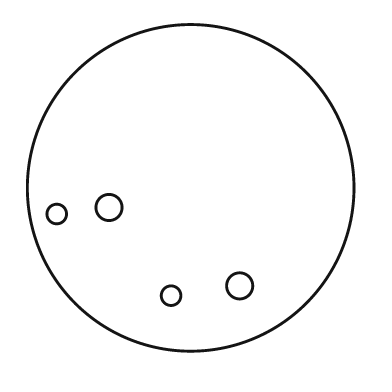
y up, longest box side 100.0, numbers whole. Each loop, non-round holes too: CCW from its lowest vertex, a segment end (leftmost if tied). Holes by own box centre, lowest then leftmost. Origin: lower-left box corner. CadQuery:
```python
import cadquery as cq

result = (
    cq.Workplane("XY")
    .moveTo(50.0, 50.0)
    .circle(50.0)
    .moveTo(44.0, 17.0)
    .circle(3.0)
    .moveTo(65.0, 20.0)
    .circle(4.0)
    .moveTo(9.0, 42.0)
    .circle(3.0)
    .moveTo(25.0, 44.0)
    .circle(4.0)
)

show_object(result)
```